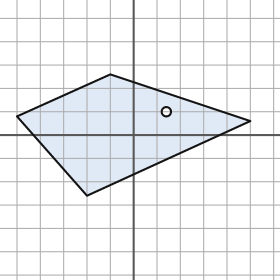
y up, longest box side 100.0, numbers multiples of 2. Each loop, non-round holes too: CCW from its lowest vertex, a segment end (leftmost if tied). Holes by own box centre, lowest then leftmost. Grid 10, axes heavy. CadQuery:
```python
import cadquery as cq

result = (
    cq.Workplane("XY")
    .moveTo(-20.0, -26.0)
    .lineTo(50.0, 6.0)
    .lineTo(-10.0, 26.0)
    .lineTo(-50.0, 8.0)
    .close()
    .moveTo(14.0, 10.0)
    .circle(2.0)
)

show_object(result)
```